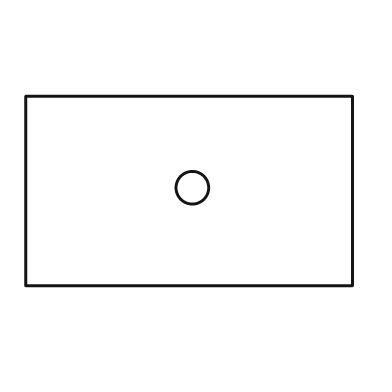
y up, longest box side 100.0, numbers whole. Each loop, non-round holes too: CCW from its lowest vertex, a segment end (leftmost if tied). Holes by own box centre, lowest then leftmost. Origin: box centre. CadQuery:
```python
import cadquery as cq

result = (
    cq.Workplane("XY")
    .moveTo(-50.0, -29.0)
    .lineTo(50.0, -29.0)
    .lineTo(50.0, 29.0)
    .lineTo(-50.0, 29.0)
    .close()
    .moveTo(1.0, 1.0)
    .circle(5.0)
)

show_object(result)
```